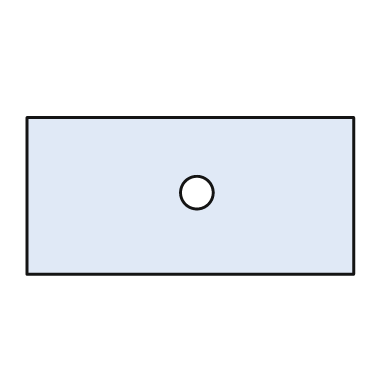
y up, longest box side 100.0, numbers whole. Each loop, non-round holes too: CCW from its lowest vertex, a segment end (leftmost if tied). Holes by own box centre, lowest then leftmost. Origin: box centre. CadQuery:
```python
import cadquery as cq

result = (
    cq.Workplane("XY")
    .moveTo(-50.0, -24.0)
    .lineTo(50.0, -24.0)
    .lineTo(50.0, 24.0)
    .lineTo(-50.0, 24.0)
    .close()
    .moveTo(2.0, 1.0)
    .circle(5.0)
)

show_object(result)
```